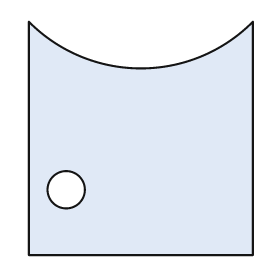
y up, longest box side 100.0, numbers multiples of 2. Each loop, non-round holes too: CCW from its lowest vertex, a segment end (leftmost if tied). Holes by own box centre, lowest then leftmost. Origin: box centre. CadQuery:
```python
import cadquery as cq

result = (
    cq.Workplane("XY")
    .moveTo(-48.0, -50.0)
    .lineTo(48.0, -50.0)
    .lineTo(48.0, 50.0)
    .threePointArc((0.0, 30.0), (-48.0, 50.0))
    .close()
    .moveTo(-32.0, -22.0)
    .circle(8.0)
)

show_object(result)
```